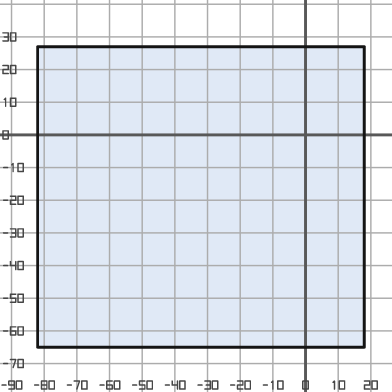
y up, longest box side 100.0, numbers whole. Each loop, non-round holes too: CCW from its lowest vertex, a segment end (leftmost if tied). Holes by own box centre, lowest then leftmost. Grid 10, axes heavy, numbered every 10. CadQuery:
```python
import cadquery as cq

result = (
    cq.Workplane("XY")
    .moveTo(-82.0, -65.0)
    .lineTo(18.0, -65.0)
    .lineTo(18.0, 27.0)
    .lineTo(-82.0, 27.0)
    .close()
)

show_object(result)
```